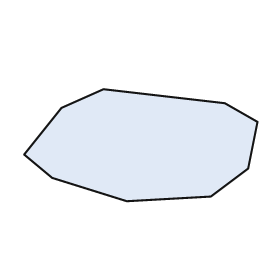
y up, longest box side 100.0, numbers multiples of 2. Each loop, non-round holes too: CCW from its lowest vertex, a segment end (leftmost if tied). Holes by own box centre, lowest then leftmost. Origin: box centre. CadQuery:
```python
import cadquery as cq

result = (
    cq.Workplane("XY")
    .moveTo(-6.0, -24.0)
    .lineTo(30.0, -22.0)
    .lineTo(46.0, -10.0)
    .lineTo(50.0, 10.0)
    .lineTo(36.0, 18.0)
    .lineTo(-16.0, 24.0)
    .lineTo(-34.0, 16.0)
    .lineTo(-50.0, -4.0)
    .lineTo(-38.0, -14.0)
    .close()
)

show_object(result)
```